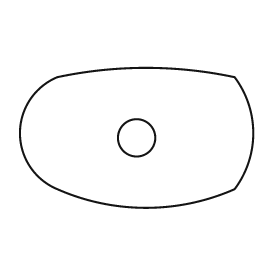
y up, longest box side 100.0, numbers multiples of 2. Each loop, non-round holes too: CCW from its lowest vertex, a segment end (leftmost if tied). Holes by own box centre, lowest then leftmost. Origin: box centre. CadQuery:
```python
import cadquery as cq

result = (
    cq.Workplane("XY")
    .moveTo(-34.0, -22.0)
    .threePointArc((4.0, -30.0), (42.0, -22.0))
    .threePointArc((50.0, 2.0), (42.0, 26.0))
    .threePointArc((4.0, 30.0), (-34.0, 26.0))
    .threePointArc((-50.0, 2.0), (-34.0, -22.0))
    .close()
    .moveTo(0.0, 0.0)
    .circle(8.0)
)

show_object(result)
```